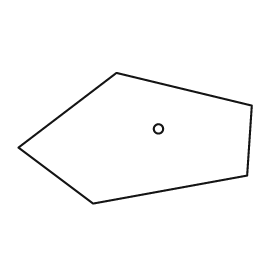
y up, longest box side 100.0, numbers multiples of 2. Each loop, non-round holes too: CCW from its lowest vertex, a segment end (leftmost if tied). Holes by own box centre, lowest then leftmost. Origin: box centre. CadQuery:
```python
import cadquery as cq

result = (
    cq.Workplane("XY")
    .moveTo(-18.0, -28.0)
    .lineTo(48.0, -16.0)
    .lineTo(50.0, 14.0)
    .lineTo(-8.0, 28.0)
    .lineTo(-50.0, -4.0)
    .close()
    .moveTo(10.0, 4.0)
    .circle(2.0)
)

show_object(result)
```